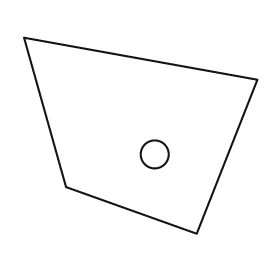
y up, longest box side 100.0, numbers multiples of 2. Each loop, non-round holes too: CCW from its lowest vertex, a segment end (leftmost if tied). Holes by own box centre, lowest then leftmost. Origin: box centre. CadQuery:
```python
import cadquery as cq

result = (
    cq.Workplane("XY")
    .moveTo(24.0, -42.0)
    .lineTo(50.0, 24.0)
    .lineTo(-50.0, 42.0)
    .lineTo(-32.0, -22.0)
    .close()
    .moveTo(6.0, -8.0)
    .circle(6.0)
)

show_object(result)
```